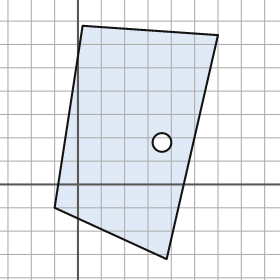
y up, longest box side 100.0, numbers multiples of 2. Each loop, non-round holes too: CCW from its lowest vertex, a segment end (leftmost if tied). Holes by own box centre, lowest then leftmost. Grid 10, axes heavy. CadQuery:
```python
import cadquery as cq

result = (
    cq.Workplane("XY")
    .moveTo(38.0, -32.0)
    .lineTo(60.0, 64.0)
    .lineTo(2.0, 68.0)
    .lineTo(-10.0, -10.0)
    .close()
    .moveTo(36.0, 18.0)
    .circle(4.0)
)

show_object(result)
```